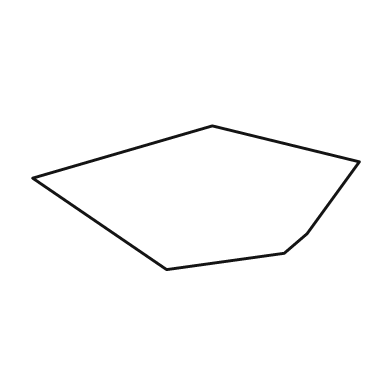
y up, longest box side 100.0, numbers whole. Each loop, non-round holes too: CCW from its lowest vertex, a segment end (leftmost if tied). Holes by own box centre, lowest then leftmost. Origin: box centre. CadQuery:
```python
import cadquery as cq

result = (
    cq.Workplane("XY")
    .moveTo(-9.0, -22.0)
    .lineTo(27.0, -17.0)
    .lineTo(34.0, -11.0)
    .lineTo(50.0, 11.0)
    .lineTo(5.0, 22.0)
    .lineTo(-50.0, 6.0)
    .close()
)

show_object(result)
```